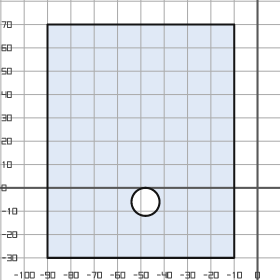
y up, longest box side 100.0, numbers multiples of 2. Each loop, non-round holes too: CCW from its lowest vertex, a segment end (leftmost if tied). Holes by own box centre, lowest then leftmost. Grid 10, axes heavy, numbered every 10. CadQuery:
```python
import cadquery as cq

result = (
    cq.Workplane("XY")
    .moveTo(-90.0, -30.0)
    .lineTo(-10.0, -30.0)
    .lineTo(-10.0, 70.0)
    .lineTo(-90.0, 70.0)
    .close()
    .moveTo(-48.0, -6.0)
    .circle(6.0)
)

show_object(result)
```